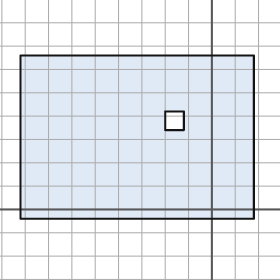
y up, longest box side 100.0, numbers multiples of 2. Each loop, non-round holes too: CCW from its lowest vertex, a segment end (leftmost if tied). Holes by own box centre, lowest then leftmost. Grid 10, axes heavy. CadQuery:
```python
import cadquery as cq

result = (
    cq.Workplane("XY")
    .moveTo(-82.0, -4.0)
    .lineTo(18.0, -4.0)
    .lineTo(18.0, 66.0)
    .lineTo(-82.0, 66.0)
    .close()
    .moveTo(-20.0, 34.0)
    .lineTo(-12.0, 34.0)
    .lineTo(-12.0, 42.0)
    .lineTo(-20.0, 42.0)
    .close()
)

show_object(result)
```